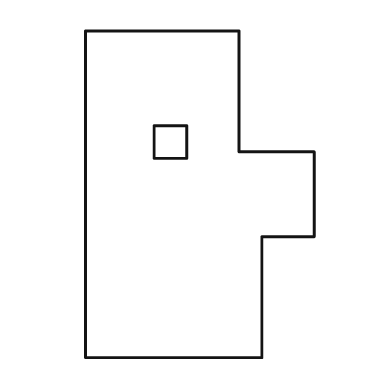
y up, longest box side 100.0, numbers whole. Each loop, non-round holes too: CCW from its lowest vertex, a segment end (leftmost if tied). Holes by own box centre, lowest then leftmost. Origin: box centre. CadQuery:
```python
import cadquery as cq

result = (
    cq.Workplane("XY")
    .moveTo(-35.0, -50.0)
    .lineTo(19.0, -50.0)
    .lineTo(19.0, -13.0)
    .lineTo(35.0, -13.0)
    .lineTo(35.0, 13.0)
    .lineTo(12.0, 13.0)
    .lineTo(12.0, 50.0)
    .lineTo(-35.0, 50.0)
    .close()
    .moveTo(-14.0, 11.0)
    .lineTo(-4.0, 11.0)
    .lineTo(-4.0, 21.0)
    .lineTo(-14.0, 21.0)
    .close()
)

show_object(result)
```